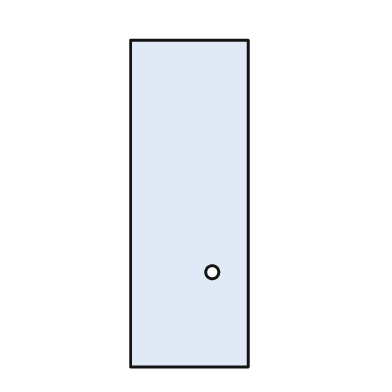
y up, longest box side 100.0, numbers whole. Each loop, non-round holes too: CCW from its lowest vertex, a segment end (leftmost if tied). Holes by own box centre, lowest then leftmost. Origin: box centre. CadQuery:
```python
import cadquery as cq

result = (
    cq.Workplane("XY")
    .moveTo(-18.0, -50.0)
    .lineTo(18.0, -50.0)
    .lineTo(18.0, 50.0)
    .lineTo(-18.0, 50.0)
    .close()
    .moveTo(7.0, -21.0)
    .circle(2.0)
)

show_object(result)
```